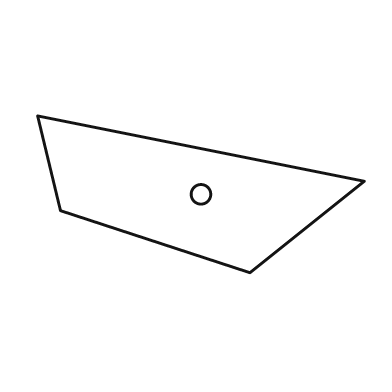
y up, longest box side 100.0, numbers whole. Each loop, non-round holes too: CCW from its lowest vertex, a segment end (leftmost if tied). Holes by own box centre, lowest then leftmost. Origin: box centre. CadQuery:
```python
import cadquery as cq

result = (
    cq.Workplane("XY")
    .moveTo(15.0, -24.0)
    .lineTo(50.0, 4.0)
    .lineTo(-50.0, 24.0)
    .lineTo(-43.0, -5.0)
    .close()
    .moveTo(0.0, 0.0)
    .circle(3.0)
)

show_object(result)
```